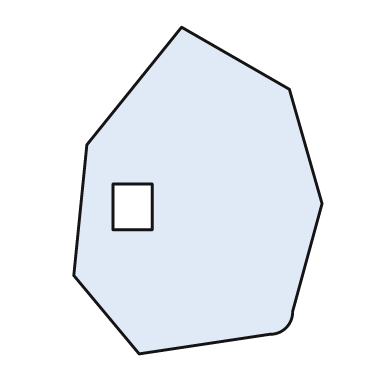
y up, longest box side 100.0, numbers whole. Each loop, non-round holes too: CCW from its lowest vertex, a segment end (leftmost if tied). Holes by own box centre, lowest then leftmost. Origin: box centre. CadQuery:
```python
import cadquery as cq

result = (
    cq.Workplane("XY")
    .moveTo(-18.0, -50.0)
    .lineTo(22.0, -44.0)
    .threePointArc((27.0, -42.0), (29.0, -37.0))
    .lineTo(38.0, -4.0)
    .lineTo(28.0, 31.0)
    .lineTo(-5.0, 50.0)
    .lineTo(-34.0, 14.0)
    .lineTo(-38.0, -26.0)
    .close()
    .moveTo(-26.0, -12.0)
    .lineTo(-14.0, -12.0)
    .lineTo(-14.0, 2.0)
    .lineTo(-26.0, 2.0)
    .close()
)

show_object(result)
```